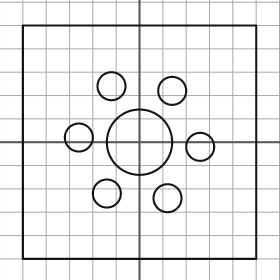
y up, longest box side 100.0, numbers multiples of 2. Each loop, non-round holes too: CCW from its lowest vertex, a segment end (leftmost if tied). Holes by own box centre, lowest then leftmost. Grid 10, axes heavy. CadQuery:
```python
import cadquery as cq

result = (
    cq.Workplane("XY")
    .moveTo(-50.0, -50.0)
    .lineTo(50.0, -50.0)
    .lineTo(50.0, 50.0)
    .lineTo(-50.0, 50.0)
    .close()
    .moveTo(12.0, -24.0)
    .circle(6.0)
    .moveTo(-14.0, -22.0)
    .circle(6.0)
    .moveTo(26.0, -2.0)
    .circle(6.0)
    .moveTo(0.0, 0.0)
    .circle(14.0)
    .moveTo(-26.0, 2.0)
    .circle(6.0)
    .moveTo(14.0, 22.0)
    .circle(6.0)
    .moveTo(-12.0, 24.0)
    .circle(6.0)
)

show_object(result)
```